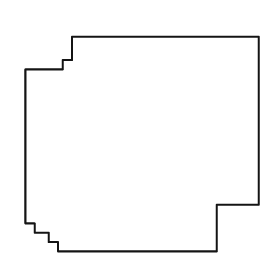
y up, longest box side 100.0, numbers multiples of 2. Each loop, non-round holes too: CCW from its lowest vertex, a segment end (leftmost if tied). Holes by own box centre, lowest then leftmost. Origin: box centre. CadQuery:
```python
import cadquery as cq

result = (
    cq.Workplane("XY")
    .moveTo(-36.0, -46.0)
    .lineTo(32.0, -46.0)
    .lineTo(32.0, -26.0)
    .lineTo(50.0, -26.0)
    .lineTo(50.0, 46.0)
    .lineTo(-30.0, 46.0)
    .lineTo(-30.0, 36.0)
    .lineTo(-34.0, 36.0)
    .lineTo(-34.0, 32.0)
    .lineTo(-50.0, 32.0)
    .lineTo(-50.0, -34.0)
    .lineTo(-46.0, -34.0)
    .lineTo(-46.0, -38.0)
    .lineTo(-40.0, -38.0)
    .lineTo(-40.0, -42.0)
    .lineTo(-36.0, -42.0)
    .close()
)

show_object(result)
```